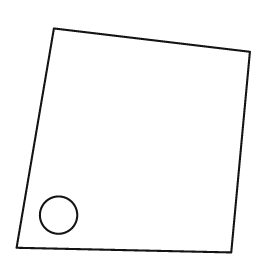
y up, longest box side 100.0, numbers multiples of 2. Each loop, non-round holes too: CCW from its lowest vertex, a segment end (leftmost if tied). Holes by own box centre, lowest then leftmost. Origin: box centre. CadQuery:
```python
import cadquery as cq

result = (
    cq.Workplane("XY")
    .moveTo(42.0, -48.0)
    .lineTo(50.0, 38.0)
    .lineTo(-34.0, 48.0)
    .lineTo(-50.0, -46.0)
    .close()
    .moveTo(-32.0, -32.0)
    .circle(8.0)
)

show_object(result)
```